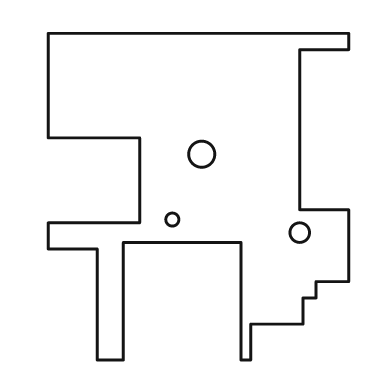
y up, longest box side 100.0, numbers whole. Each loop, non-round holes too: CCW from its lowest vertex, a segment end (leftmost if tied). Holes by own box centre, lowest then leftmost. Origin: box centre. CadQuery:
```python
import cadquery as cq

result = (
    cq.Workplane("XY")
    .moveTo(-31.0, -50.0)
    .lineTo(-23.0, -50.0)
    .lineTo(-23.0, -14.0)
    .lineTo(13.0, -14.0)
    .lineTo(13.0, -50.0)
    .lineTo(16.0, -50.0)
    .lineTo(16.0, -39.0)
    .lineTo(32.0, -39.0)
    .lineTo(32.0, -31.0)
    .lineTo(36.0, -31.0)
    .lineTo(36.0, -26.0)
    .lineTo(46.0, -26.0)
    .lineTo(46.0, -4.0)
    .lineTo(31.0, -4.0)
    .lineTo(31.0, 45.0)
    .lineTo(46.0, 45.0)
    .lineTo(46.0, 50.0)
    .lineTo(-46.0, 50.0)
    .lineTo(-46.0, 18.0)
    .lineTo(-18.0, 18.0)
    .lineTo(-18.0, -8.0)
    .lineTo(-46.0, -8.0)
    .lineTo(-46.0, -16.0)
    .lineTo(-31.0, -16.0)
    .close()
    .moveTo(31.0, -11.0)
    .circle(3.0)
    .moveTo(-8.0, -7.0)
    .circle(2.0)
    .moveTo(1.0, 13.0)
    .circle(4.0)
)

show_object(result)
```